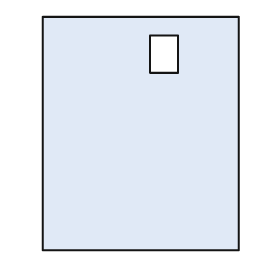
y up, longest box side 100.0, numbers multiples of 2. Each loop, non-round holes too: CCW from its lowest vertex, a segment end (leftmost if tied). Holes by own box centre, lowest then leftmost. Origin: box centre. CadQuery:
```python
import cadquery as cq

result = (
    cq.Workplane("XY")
    .moveTo(-42.0, -50.0)
    .lineTo(42.0, -50.0)
    .lineTo(42.0, 50.0)
    .lineTo(-42.0, 50.0)
    .close()
    .moveTo(4.0, 26.0)
    .lineTo(16.0, 26.0)
    .lineTo(16.0, 42.0)
    .lineTo(4.0, 42.0)
    .close()
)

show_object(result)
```